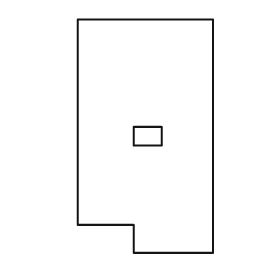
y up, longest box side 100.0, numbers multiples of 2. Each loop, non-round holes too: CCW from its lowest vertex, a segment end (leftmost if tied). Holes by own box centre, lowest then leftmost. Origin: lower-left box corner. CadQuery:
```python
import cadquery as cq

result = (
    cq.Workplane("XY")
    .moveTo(24.0, 0.0)
    .lineTo(58.0, 0.0)
    .lineTo(58.0, 100.0)
    .lineTo(0.0, 100.0)
    .lineTo(0.0, 12.0)
    .lineTo(24.0, 12.0)
    .close()
    .moveTo(24.0, 46.0)
    .lineTo(36.0, 46.0)
    .lineTo(36.0, 54.0)
    .lineTo(24.0, 54.0)
    .close()
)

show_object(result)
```